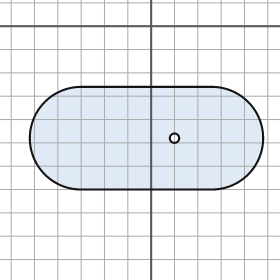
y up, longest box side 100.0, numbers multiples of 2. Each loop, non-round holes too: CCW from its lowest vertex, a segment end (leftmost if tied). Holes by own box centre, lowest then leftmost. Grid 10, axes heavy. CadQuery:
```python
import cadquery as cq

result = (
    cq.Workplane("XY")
    .moveTo(-30.0, -70.0)
    .lineTo(26.0, -70.0)
    .threePointArc((48.0, -48.0), (26.0, -26.0))
    .lineTo(-30.0, -26.0)
    .threePointArc((-52.0, -48.0), (-30.0, -70.0))
    .close()
    .moveTo(10.0, -48.0)
    .circle(2.0)
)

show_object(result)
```